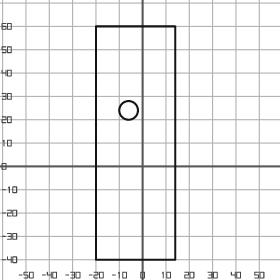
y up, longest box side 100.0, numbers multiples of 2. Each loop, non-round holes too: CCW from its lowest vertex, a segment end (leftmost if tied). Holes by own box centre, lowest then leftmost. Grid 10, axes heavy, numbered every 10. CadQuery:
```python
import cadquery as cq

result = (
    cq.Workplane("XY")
    .moveTo(-20.0, -40.0)
    .lineTo(14.0, -40.0)
    .lineTo(14.0, 60.0)
    .lineTo(-20.0, 60.0)
    .close()
    .moveTo(-6.0, 24.0)
    .circle(4.0)
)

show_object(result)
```